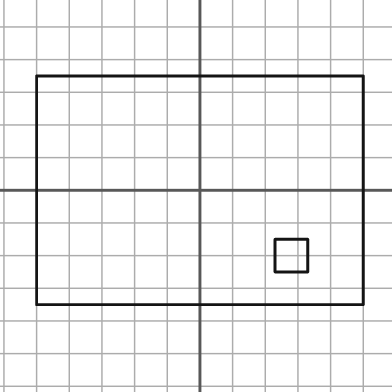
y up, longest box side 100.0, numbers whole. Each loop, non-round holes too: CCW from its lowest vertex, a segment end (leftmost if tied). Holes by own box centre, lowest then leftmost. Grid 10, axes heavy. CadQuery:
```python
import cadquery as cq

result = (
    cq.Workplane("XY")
    .moveTo(-50.0, -35.0)
    .lineTo(50.0, -35.0)
    .lineTo(50.0, 35.0)
    .lineTo(-50.0, 35.0)
    .close()
    .moveTo(23.0, -25.0)
    .lineTo(33.0, -25.0)
    .lineTo(33.0, -15.0)
    .lineTo(23.0, -15.0)
    .close()
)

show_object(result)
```